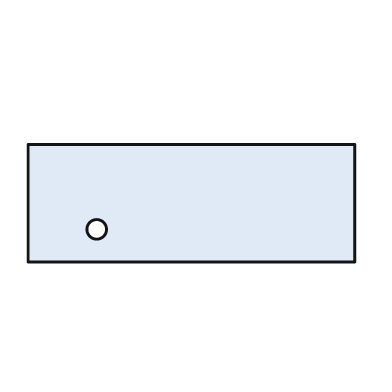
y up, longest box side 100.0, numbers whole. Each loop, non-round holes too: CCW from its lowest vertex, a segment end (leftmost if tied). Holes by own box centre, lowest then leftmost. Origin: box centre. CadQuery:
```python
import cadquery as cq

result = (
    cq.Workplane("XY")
    .moveTo(-50.0, -18.0)
    .lineTo(50.0, -18.0)
    .lineTo(50.0, 18.0)
    .lineTo(-50.0, 18.0)
    .close()
    .moveTo(-29.0, -8.0)
    .circle(3.0)
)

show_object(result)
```